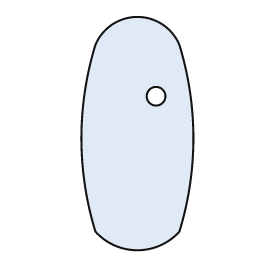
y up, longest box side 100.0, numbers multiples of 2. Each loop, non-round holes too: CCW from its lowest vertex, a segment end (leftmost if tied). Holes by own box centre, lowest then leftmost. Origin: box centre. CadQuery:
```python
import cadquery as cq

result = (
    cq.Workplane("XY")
    .moveTo(-18.0, -42.0)
    .threePointArc((0.0, -50.0), (18.0, -42.0))
    .threePointArc((24.0, -2.0), (18.0, 38.0))
    .threePointArc((0.0, 50.0), (-18.0, 38.0))
    .threePointArc((-24.0, -2.0), (-18.0, -42.0))
    .close()
    .moveTo(8.0, 16.0)
    .circle(4.0)
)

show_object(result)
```